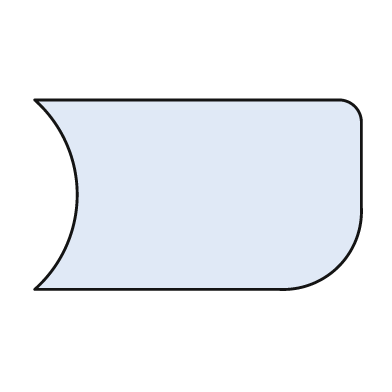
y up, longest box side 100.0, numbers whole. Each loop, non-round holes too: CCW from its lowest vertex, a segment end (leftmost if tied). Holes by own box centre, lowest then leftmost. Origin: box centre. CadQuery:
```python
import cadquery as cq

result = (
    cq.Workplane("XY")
    .moveTo(-50.0, -29.0)
    .lineTo(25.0, -29.0)
    .threePointArc((43.0, -22.0), (50.0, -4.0))
    .lineTo(50.0, 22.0)
    .threePointArc((48.0, 27.0), (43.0, 29.0))
    .lineTo(-50.0, 29.0)
    .threePointArc((-37.0, 0.0), (-50.0, -29.0))
    .close()
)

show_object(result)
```